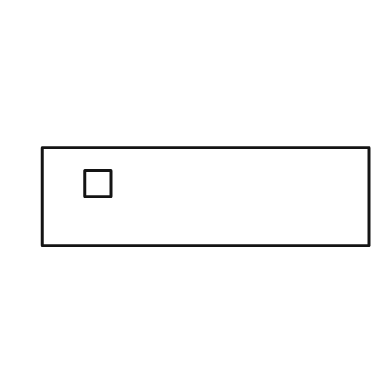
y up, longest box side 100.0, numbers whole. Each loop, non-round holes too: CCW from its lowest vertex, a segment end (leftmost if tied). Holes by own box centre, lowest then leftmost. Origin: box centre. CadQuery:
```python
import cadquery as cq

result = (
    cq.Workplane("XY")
    .moveTo(-50.0, -15.0)
    .lineTo(50.0, -15.0)
    .lineTo(50.0, 15.0)
    .lineTo(-50.0, 15.0)
    .close()
    .moveTo(-37.0, 0.0)
    .lineTo(-29.0, 0.0)
    .lineTo(-29.0, 8.0)
    .lineTo(-37.0, 8.0)
    .close()
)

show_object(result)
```